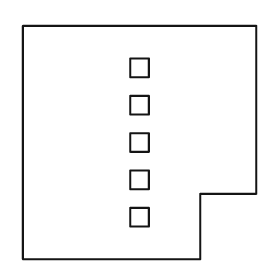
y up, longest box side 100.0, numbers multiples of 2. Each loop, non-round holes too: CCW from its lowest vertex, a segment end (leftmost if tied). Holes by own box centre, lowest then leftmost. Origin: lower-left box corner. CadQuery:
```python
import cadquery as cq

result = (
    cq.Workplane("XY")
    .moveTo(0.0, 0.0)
    .lineTo(76.0, 0.0)
    .lineTo(76.0, 28.0)
    .lineTo(100.0, 28.0)
    .lineTo(100.0, 100.0)
    .lineTo(0.0, 100.0)
    .close()
    .moveTo(46.0, 14.0)
    .lineTo(54.0, 14.0)
    .lineTo(54.0, 22.0)
    .lineTo(46.0, 22.0)
    .close()
    .moveTo(46.0, 30.0)
    .lineTo(54.0, 30.0)
    .lineTo(54.0, 38.0)
    .lineTo(46.0, 38.0)
    .close()
    .moveTo(46.0, 46.0)
    .lineTo(54.0, 46.0)
    .lineTo(54.0, 54.0)
    .lineTo(46.0, 54.0)
    .close()
    .moveTo(46.0, 62.0)
    .lineTo(54.0, 62.0)
    .lineTo(54.0, 70.0)
    .lineTo(46.0, 70.0)
    .close()
    .moveTo(46.0, 78.0)
    .lineTo(54.0, 78.0)
    .lineTo(54.0, 86.0)
    .lineTo(46.0, 86.0)
    .close()
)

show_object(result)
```